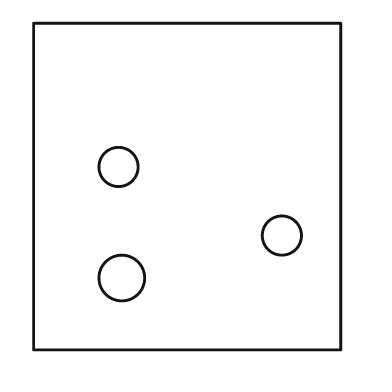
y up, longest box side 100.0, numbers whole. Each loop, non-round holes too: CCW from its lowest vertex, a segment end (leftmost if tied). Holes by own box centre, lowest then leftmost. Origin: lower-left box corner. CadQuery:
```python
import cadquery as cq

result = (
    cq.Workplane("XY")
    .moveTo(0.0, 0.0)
    .lineTo(94.0, 0.0)
    .lineTo(94.0, 100.0)
    .lineTo(0.0, 100.0)
    .close()
    .moveTo(27.0, 22.0)
    .circle(7.0)
    .moveTo(76.0, 35.0)
    .circle(6.0)
    .moveTo(26.0, 56.0)
    .circle(6.0)
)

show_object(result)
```